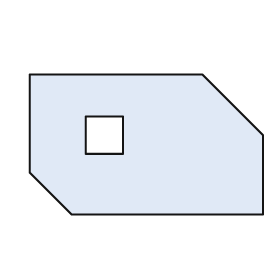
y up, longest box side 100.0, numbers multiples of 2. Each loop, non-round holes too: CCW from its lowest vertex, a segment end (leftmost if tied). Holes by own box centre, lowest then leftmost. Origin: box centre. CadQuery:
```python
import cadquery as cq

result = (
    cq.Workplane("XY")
    .moveTo(-32.0, -30.0)
    .lineTo(50.0, -30.0)
    .lineTo(50.0, 4.0)
    .lineTo(24.0, 30.0)
    .lineTo(-50.0, 30.0)
    .lineTo(-50.0, -12.0)
    .close()
    .moveTo(-26.0, -4.0)
    .lineTo(-10.0, -4.0)
    .lineTo(-10.0, 12.0)
    .lineTo(-26.0, 12.0)
    .close()
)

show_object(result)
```